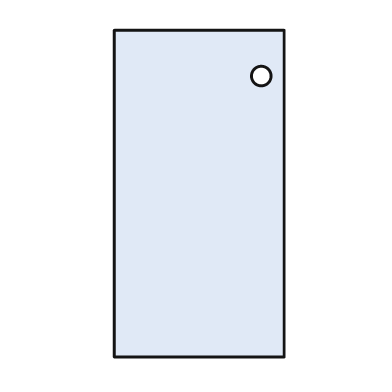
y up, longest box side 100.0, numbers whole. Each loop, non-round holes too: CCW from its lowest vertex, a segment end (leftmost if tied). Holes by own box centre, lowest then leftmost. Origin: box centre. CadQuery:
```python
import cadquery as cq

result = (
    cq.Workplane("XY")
    .moveTo(-26.0, -50.0)
    .lineTo(26.0, -50.0)
    .lineTo(26.0, 50.0)
    .lineTo(-26.0, 50.0)
    .close()
    .moveTo(19.0, 36.0)
    .circle(3.0)
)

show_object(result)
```